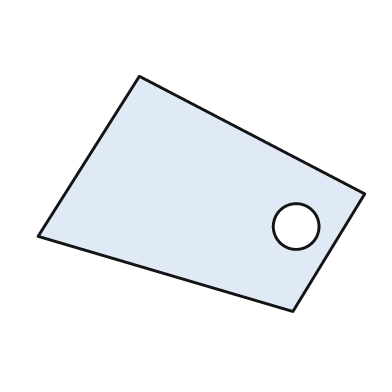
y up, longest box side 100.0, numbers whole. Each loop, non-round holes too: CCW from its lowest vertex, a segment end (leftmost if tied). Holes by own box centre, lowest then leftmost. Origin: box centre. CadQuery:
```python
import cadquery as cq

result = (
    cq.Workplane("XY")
    .moveTo(28.0, -36.0)
    .lineTo(50.0, 0.0)
    .lineTo(-19.0, 36.0)
    .lineTo(-50.0, -13.0)
    .close()
    .moveTo(29.0, -10.0)
    .circle(7.0)
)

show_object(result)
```